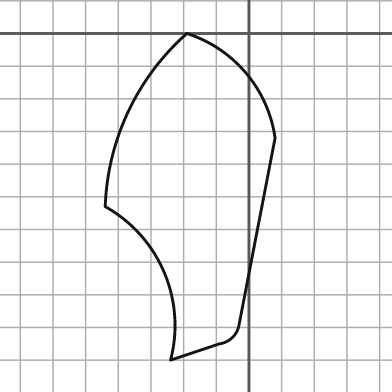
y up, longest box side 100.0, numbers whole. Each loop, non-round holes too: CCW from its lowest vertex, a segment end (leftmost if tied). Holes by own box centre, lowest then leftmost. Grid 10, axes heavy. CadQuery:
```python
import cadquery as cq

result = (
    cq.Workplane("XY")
    .moveTo(-24.0, -100.0)
    .lineTo(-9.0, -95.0)
    .threePointArc((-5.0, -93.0), (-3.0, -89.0))
    .lineTo(8.0, -32.0)
    .threePointArc((-1.0, -12.0), (-19.0, 0.0))
    .threePointArc((-37.0, -24.0), (-44.0, -53.0))
    .threePointArc((-26.0, -73.0), (-24.0, -100.0))
    .close()
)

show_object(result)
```